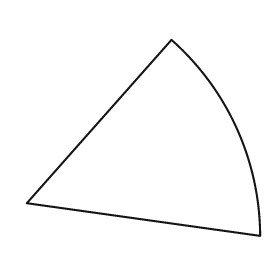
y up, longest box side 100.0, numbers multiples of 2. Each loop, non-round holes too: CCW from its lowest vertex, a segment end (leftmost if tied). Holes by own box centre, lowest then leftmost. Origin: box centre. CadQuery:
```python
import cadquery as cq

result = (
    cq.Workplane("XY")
    .moveTo(50.0, -42.0)
    .threePointArc((40.0, 4.0), (12.0, 42.0))
    .lineTo(-50.0, -28.0)
    .close()
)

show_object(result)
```